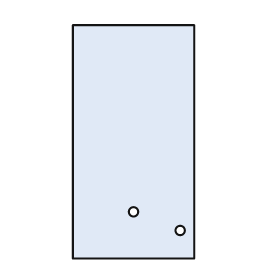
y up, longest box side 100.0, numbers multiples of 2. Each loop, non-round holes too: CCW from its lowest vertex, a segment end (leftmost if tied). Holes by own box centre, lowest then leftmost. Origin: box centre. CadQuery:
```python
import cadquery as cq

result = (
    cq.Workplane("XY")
    .moveTo(-26.0, -50.0)
    .lineTo(26.0, -50.0)
    .lineTo(26.0, 50.0)
    .lineTo(-26.0, 50.0)
    .close()
    .moveTo(20.0, -38.0)
    .circle(2.0)
    .moveTo(0.0, -30.0)
    .circle(2.0)
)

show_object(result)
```